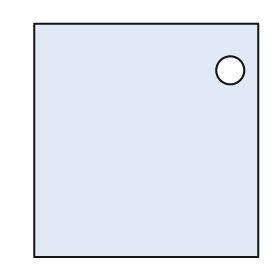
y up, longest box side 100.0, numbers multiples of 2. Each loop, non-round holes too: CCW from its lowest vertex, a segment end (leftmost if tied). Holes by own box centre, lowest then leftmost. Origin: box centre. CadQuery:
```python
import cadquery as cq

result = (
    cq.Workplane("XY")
    .moveTo(-48.0, -50.0)
    .lineTo(48.0, -50.0)
    .lineTo(48.0, 50.0)
    .lineTo(-48.0, 50.0)
    .close()
    .moveTo(36.0, 30.0)
    .circle(6.0)
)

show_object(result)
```